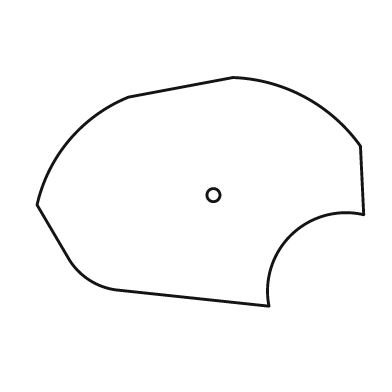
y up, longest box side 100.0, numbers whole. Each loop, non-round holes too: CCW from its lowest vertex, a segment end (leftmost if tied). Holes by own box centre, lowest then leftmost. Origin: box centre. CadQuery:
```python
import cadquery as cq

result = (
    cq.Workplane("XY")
    .moveTo(21.0, -35.0)
    .threePointArc((28.0, -13.0), (50.0, -7.0))
    .lineTo(49.0, 14.0)
    .threePointArc((32.0, 29.0), (10.0, 35.0))
    .lineTo(-22.0, 29.0)
    .threePointArc((-40.0, 16.0), (-50.0, -4.0))
    .lineTo(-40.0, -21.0)
    .threePointArc((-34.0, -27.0), (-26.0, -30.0))
    .close()
    .moveTo(4.0, -1.0)
    .circle(2.0)
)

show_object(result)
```